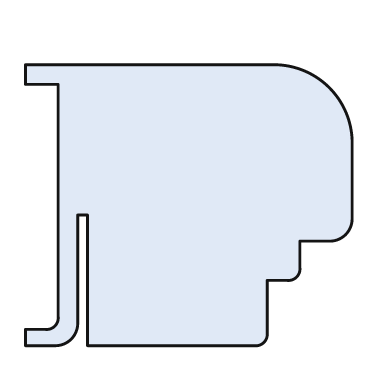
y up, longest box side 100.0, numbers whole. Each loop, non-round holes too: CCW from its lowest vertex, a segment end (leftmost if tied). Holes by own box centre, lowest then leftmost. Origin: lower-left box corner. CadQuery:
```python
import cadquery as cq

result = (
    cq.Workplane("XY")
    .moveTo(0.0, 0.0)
    .lineTo(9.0, 0.0)
    .threePointArc((14.0, 2.0), (16.0, 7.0))
    .lineTo(16.0, 40.0)
    .lineTo(19.0, 40.0)
    .lineTo(19.0, 0.0)
    .lineTo(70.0, 0.0)
    .threePointArc((73.0, 1.0), (74.0, 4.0))
    .lineTo(74.0, 20.0)
    .lineTo(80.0, 20.0)
    .threePointArc((83.0, 21.0), (84.0, 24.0))
    .lineTo(84.0, 32.0)
    .lineTo(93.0, 32.0)
    .threePointArc((98.0, 34.0), (100.0, 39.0))
    .lineTo(100.0, 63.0)
    .threePointArc((93.0, 79.0), (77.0, 86.0))
    .lineTo(0.0, 86.0)
    .lineTo(0.0, 80.0)
    .lineTo(10.0, 80.0)
    .lineTo(10.0, 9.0)
    .threePointArc((9.0, 6.0), (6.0, 5.0))
    .lineTo(0.0, 5.0)
    .close()
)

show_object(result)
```